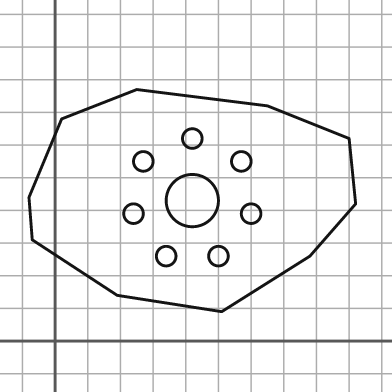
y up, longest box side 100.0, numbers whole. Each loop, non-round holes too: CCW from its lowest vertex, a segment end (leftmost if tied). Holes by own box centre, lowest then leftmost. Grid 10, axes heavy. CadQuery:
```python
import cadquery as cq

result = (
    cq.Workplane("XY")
    .moveTo(51.0, 9.0)
    .lineTo(78.0, 26.0)
    .lineTo(92.0, 42.0)
    .lineTo(90.0, 62.0)
    .lineTo(65.0, 72.0)
    .lineTo(25.0, 77.0)
    .lineTo(2.0, 68.0)
    .lineTo(-8.0, 44.0)
    .lineTo(-7.0, 31.0)
    .lineTo(19.0, 14.0)
    .close()
    .moveTo(34.0, 26.0)
    .circle(3.0)
    .moveTo(50.0, 26.0)
    .circle(3.0)
    .moveTo(24.0, 39.0)
    .circle(3.0)
    .moveTo(60.0, 39.0)
    .circle(3.0)
    .moveTo(42.0, 43.0)
    .circle(8.0)
    .moveTo(27.0, 55.0)
    .circle(3.0)
    .moveTo(57.0, 55.0)
    .circle(3.0)
    .moveTo(42.0, 62.0)
    .circle(3.0)
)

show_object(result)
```